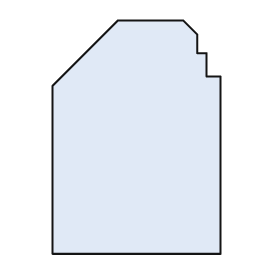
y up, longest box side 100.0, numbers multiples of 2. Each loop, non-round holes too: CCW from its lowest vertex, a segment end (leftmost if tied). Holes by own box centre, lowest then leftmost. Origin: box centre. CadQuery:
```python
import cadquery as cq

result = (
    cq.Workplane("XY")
    .moveTo(-36.0, -50.0)
    .lineTo(36.0, -50.0)
    .lineTo(36.0, 26.0)
    .lineTo(30.0, 26.0)
    .lineTo(30.0, 36.0)
    .lineTo(26.0, 36.0)
    .lineTo(26.0, 44.0)
    .lineTo(20.0, 50.0)
    .lineTo(-8.0, 50.0)
    .lineTo(-36.0, 22.0)
    .close()
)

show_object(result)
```